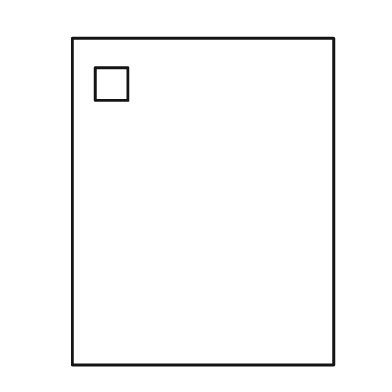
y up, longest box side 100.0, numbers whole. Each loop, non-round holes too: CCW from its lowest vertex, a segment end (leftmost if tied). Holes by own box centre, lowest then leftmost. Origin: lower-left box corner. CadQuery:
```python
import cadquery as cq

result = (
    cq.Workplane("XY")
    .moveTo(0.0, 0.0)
    .lineTo(80.0, 0.0)
    .lineTo(80.0, 100.0)
    .lineTo(0.0, 100.0)
    .close()
    .moveTo(7.0, 81.0)
    .lineTo(17.0, 81.0)
    .lineTo(17.0, 91.0)
    .lineTo(7.0, 91.0)
    .close()
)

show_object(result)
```